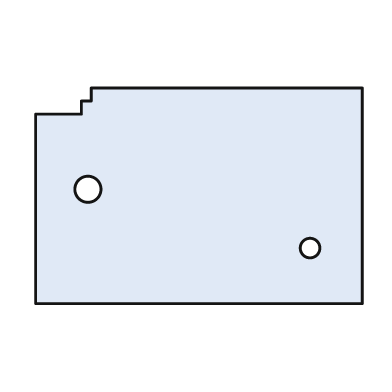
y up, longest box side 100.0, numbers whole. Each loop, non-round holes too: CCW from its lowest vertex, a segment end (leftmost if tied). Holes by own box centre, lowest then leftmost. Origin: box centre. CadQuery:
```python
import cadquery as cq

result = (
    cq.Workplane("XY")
    .moveTo(-50.0, -33.0)
    .lineTo(50.0, -33.0)
    .lineTo(50.0, 33.0)
    .lineTo(-33.0, 33.0)
    .lineTo(-33.0, 29.0)
    .lineTo(-36.0, 29.0)
    .lineTo(-36.0, 25.0)
    .lineTo(-50.0, 25.0)
    .close()
    .moveTo(34.0, -16.0)
    .circle(3.0)
    .moveTo(-34.0, 2.0)
    .circle(4.0)
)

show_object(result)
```